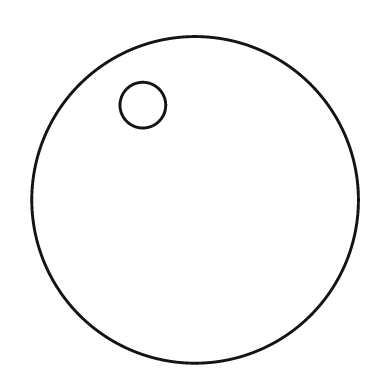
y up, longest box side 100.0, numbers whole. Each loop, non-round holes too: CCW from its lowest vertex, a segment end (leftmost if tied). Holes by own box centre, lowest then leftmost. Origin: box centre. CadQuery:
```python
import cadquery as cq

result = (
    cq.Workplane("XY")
    .moveTo(0.0, 0.0)
    .circle(50.0)
    .moveTo(-16.0, 29.0)
    .circle(7.0)
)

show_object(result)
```